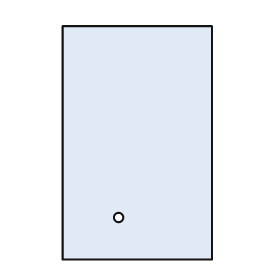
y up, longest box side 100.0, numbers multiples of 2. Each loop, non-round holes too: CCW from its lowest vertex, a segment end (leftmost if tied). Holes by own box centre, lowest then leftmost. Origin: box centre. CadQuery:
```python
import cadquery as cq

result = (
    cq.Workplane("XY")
    .moveTo(-32.0, -50.0)
    .lineTo(32.0, -50.0)
    .lineTo(32.0, 50.0)
    .lineTo(-32.0, 50.0)
    .close()
    .moveTo(-8.0, -32.0)
    .circle(2.0)
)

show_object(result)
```